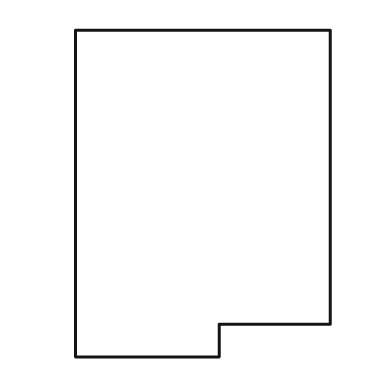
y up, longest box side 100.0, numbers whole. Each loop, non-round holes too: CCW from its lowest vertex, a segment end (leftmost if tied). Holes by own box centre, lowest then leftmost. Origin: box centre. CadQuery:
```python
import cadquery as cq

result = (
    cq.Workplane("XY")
    .moveTo(-39.0, -50.0)
    .lineTo(5.0, -50.0)
    .lineTo(5.0, -40.0)
    .lineTo(39.0, -40.0)
    .lineTo(39.0, 50.0)
    .lineTo(-39.0, 50.0)
    .close()
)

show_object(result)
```